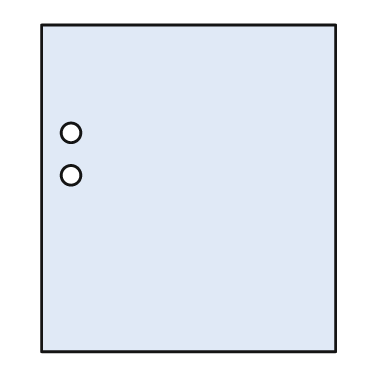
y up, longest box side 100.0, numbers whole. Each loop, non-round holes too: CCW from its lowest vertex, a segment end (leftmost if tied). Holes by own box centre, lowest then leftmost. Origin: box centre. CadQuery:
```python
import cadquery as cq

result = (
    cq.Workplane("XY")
    .moveTo(-45.0, -50.0)
    .lineTo(45.0, -50.0)
    .lineTo(45.0, 50.0)
    .lineTo(-45.0, 50.0)
    .close()
    .moveTo(-36.0, 4.0)
    .circle(3.0)
    .moveTo(-36.0, 17.0)
    .circle(3.0)
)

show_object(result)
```